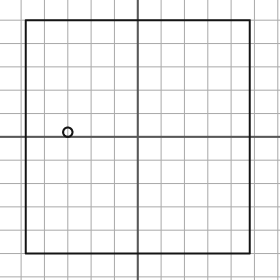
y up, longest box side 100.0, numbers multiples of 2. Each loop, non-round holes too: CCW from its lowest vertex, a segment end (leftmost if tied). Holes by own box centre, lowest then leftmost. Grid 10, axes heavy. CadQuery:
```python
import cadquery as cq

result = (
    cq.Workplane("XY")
    .moveTo(-48.0, -50.0)
    .lineTo(48.0, -50.0)
    .lineTo(48.0, 50.0)
    .lineTo(-48.0, 50.0)
    .close()
    .moveTo(-30.0, 2.0)
    .circle(2.0)
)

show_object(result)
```